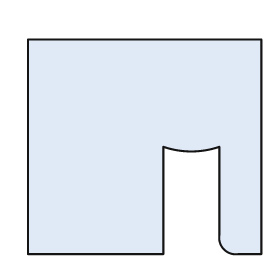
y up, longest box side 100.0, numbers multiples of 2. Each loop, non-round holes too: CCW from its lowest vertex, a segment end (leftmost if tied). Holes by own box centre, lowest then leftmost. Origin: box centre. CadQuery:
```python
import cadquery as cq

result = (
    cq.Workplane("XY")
    .moveTo(-50.0, -46.0)
    .lineTo(8.0, -46.0)
    .lineTo(8.0, 0.0)
    .threePointArc((20.0, -2.0), (32.0, 0.0))
    .lineTo(32.0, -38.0)
    .threePointArc((34.0, -44.0), (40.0, -46.0))
    .lineTo(50.0, -46.0)
    .lineTo(50.0, 46.0)
    .lineTo(-50.0, 46.0)
    .close()
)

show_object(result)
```